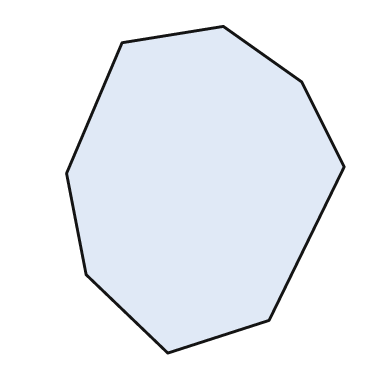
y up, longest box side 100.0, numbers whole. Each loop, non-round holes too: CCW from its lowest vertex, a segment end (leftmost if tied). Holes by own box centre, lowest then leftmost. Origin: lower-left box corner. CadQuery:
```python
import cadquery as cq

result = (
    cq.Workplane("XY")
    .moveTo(31.0, 0.0)
    .lineTo(62.0, 10.0)
    .lineTo(85.0, 57.0)
    .lineTo(72.0, 83.0)
    .lineTo(48.0, 100.0)
    .lineTo(17.0, 95.0)
    .lineTo(0.0, 55.0)
    .lineTo(6.0, 24.0)
    .close()
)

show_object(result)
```